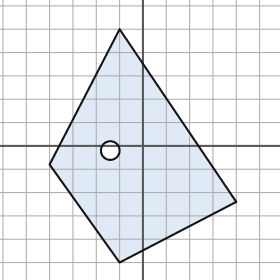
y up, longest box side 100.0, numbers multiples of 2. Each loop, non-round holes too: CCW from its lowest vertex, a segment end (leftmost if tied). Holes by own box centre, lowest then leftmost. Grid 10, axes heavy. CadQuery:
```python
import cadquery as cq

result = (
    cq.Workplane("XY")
    .moveTo(-10.0, -50.0)
    .lineTo(40.0, -24.0)
    .lineTo(-10.0, 50.0)
    .lineTo(-40.0, -8.0)
    .close()
    .moveTo(-14.0, -2.0)
    .circle(4.0)
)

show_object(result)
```